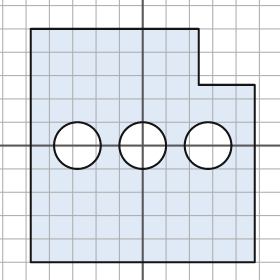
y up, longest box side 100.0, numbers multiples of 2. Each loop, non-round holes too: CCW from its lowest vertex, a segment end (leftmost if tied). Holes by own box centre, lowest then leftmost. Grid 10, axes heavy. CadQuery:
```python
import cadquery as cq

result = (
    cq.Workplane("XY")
    .moveTo(-48.0, -50.0)
    .lineTo(48.0, -50.0)
    .lineTo(48.0, 26.0)
    .lineTo(24.0, 26.0)
    .lineTo(24.0, 50.0)
    .lineTo(-48.0, 50.0)
    .close()
    .moveTo(-28.0, 0.0)
    .circle(10.0)
    .moveTo(0.0, 0.0)
    .circle(10.0)
    .moveTo(28.0, 0.0)
    .circle(10.0)
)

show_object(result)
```